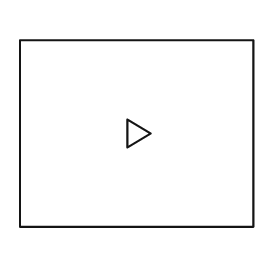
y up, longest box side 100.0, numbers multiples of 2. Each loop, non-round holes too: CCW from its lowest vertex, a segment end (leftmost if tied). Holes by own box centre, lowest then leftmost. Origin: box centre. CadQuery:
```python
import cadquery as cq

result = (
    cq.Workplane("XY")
    .moveTo(-50.0, -40.0)
    .lineTo(50.0, -40.0)
    .lineTo(50.0, 40.0)
    .lineTo(-50.0, 40.0)
    .close()
    .moveTo(-4.0, -6.0)
    .lineTo(6.0, 0.0)
    .lineTo(-4.0, 6.0)
    .close()
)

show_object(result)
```